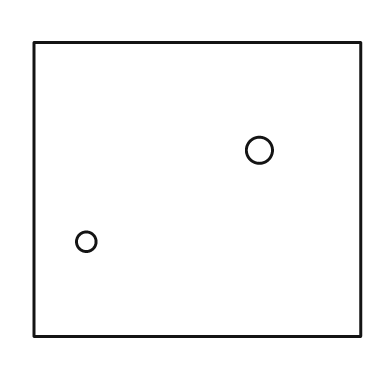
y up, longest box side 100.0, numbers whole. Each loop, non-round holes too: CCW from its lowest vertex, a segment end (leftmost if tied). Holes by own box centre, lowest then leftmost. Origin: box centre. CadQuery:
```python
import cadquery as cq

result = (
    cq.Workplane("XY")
    .moveTo(-50.0, -45.0)
    .lineTo(50.0, -45.0)
    .lineTo(50.0, 45.0)
    .lineTo(-50.0, 45.0)
    .close()
    .moveTo(-34.0, -16.0)
    .circle(3.0)
    .moveTo(19.0, 12.0)
    .circle(4.0)
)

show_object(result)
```